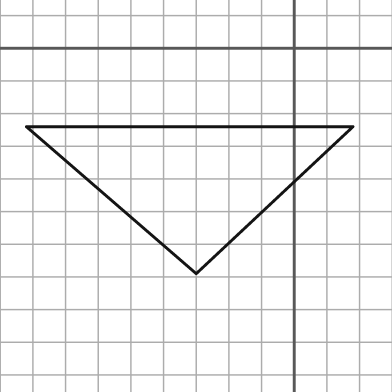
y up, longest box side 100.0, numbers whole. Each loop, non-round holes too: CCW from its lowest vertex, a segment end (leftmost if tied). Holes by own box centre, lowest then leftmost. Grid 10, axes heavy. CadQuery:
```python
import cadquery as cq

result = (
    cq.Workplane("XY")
    .moveTo(-30.0, -69.0)
    .lineTo(18.0, -24.0)
    .lineTo(-82.0, -24.0)
    .close()
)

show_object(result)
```